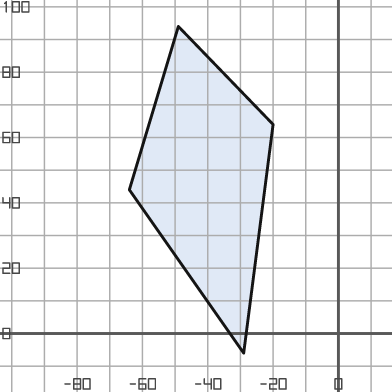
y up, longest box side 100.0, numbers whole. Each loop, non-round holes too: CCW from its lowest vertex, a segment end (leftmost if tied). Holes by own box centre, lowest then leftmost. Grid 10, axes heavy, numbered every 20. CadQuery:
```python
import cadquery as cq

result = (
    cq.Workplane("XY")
    .moveTo(-29.0, -6.0)
    .lineTo(-20.0, 64.0)
    .lineTo(-49.0, 94.0)
    .lineTo(-64.0, 44.0)
    .close()
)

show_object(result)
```